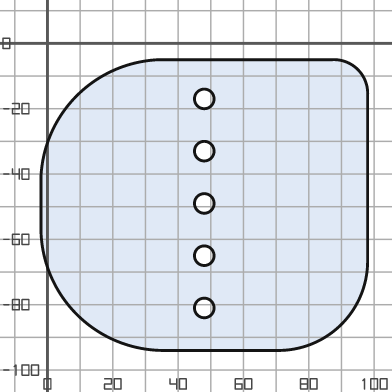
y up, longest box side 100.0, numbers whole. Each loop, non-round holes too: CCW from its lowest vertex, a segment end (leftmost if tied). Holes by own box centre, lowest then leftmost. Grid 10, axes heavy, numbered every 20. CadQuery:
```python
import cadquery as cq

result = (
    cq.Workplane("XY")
    .moveTo(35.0, -94.0)
    .lineTo(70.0, -94.0)
    .threePointArc((90.0, -86.0), (98.0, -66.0))
    .lineTo(98.0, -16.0)
    .threePointArc((95.0, -8.0), (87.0, -5.0))
    .lineTo(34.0, -5.0)
    .threePointArc((9.0, -16.0), (-2.0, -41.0))
    .lineTo(-2.0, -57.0)
    .threePointArc((9.0, -83.0), (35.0, -94.0))
    .close()
    .moveTo(48.0, -81.0)
    .circle(3.0)
    .moveTo(48.0, -65.0)
    .circle(3.0)
    .moveTo(48.0, -49.0)
    .circle(3.0)
    .moveTo(48.0, -33.0)
    .circle(3.0)
    .moveTo(48.0, -17.0)
    .circle(3.0)
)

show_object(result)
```